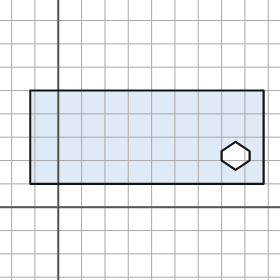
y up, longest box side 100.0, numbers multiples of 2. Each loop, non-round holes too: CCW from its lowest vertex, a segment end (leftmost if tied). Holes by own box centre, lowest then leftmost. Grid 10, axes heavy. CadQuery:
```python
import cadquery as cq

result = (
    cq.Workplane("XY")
    .moveTo(-12.0, 10.0)
    .lineTo(88.0, 10.0)
    .lineTo(88.0, 50.0)
    .lineTo(-12.0, 50.0)
    .close()
    .moveTo(76.0, 16.0)
    .lineTo(82.0, 20.0)
    .lineTo(82.0, 24.0)
    .lineTo(76.0, 28.0)
    .lineTo(70.0, 24.0)
    .lineTo(70.0, 20.0)
    .close()
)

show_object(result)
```